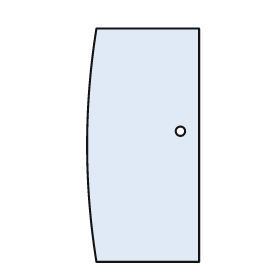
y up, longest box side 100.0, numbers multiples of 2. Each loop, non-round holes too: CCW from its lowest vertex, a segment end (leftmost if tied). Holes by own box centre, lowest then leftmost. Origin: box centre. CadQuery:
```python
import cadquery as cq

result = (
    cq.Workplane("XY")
    .moveTo(-20.0, -50.0)
    .lineTo(24.0, -50.0)
    .lineTo(24.0, 50.0)
    .lineTo(-20.0, 50.0)
    .threePointArc((-24.0, 0.0), (-20.0, -50.0))
    .close()
    .moveTo(16.0, 6.0)
    .circle(2.0)
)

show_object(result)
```